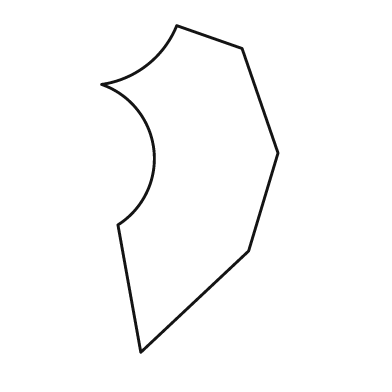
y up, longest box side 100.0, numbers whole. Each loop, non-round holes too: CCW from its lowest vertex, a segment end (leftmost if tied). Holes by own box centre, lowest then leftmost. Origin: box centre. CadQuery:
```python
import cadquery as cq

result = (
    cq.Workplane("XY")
    .moveTo(-15.0, -50.0)
    .lineTo(18.0, -19.0)
    .lineTo(27.0, 11.0)
    .lineTo(16.0, 43.0)
    .lineTo(-4.0, 50.0)
    .threePointArc((-13.0, 38.0), (-27.0, 32.0))
    .threePointArc((-11.0, 12.0), (-22.0, -11.0))
    .close()
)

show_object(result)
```